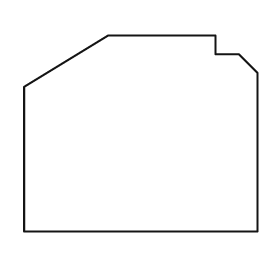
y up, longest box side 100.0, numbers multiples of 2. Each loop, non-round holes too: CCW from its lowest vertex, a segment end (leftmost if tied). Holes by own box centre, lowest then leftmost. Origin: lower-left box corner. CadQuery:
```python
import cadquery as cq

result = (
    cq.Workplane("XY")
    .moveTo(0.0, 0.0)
    .lineTo(100.0, 0.0)
    .lineTo(100.0, 68.0)
    .lineTo(92.0, 76.0)
    .lineTo(82.0, 76.0)
    .lineTo(82.0, 84.0)
    .lineTo(36.0, 84.0)
    .lineTo(0.0, 62.0)
    .close()
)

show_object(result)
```